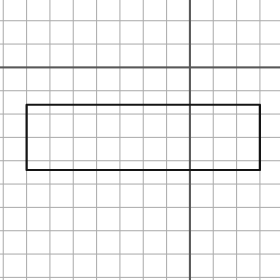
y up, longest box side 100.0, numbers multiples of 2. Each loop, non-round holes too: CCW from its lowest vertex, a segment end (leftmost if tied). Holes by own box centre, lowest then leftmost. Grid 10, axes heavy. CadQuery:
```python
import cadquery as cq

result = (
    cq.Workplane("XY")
    .moveTo(-70.0, -44.0)
    .lineTo(30.0, -44.0)
    .lineTo(30.0, -16.0)
    .lineTo(-70.0, -16.0)
    .close()
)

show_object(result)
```